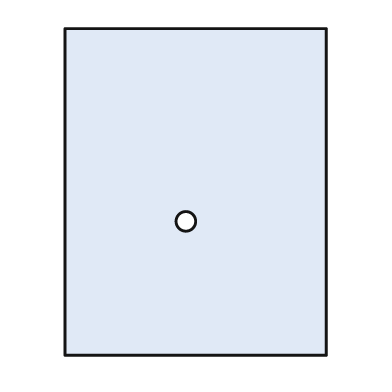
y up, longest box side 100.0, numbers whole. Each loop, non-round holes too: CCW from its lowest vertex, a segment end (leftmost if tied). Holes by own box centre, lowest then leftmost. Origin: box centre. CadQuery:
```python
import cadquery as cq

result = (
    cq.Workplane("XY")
    .moveTo(-40.0, -50.0)
    .lineTo(40.0, -50.0)
    .lineTo(40.0, 50.0)
    .lineTo(-40.0, 50.0)
    .close()
    .moveTo(-3.0, -9.0)
    .circle(3.0)
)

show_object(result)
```